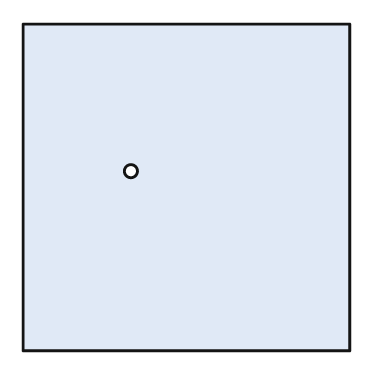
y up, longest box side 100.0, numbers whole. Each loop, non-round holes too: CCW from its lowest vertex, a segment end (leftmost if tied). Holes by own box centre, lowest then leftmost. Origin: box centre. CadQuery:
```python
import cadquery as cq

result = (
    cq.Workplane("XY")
    .moveTo(-50.0, -50.0)
    .lineTo(50.0, -50.0)
    .lineTo(50.0, 50.0)
    .lineTo(-50.0, 50.0)
    .close()
    .moveTo(-17.0, 5.0)
    .circle(2.0)
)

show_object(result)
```